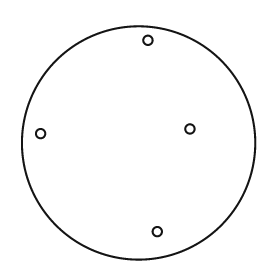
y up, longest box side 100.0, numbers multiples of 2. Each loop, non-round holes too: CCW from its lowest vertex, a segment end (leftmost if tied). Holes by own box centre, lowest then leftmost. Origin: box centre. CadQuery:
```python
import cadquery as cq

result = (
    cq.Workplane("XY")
    .moveTo(0.0, 0.0)
    .circle(50.0)
    .moveTo(8.0, -38.0)
    .circle(2.0)
    .moveTo(-42.0, 4.0)
    .circle(2.0)
    .moveTo(22.0, 6.0)
    .circle(2.0)
    .moveTo(4.0, 44.0)
    .circle(2.0)
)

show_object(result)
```